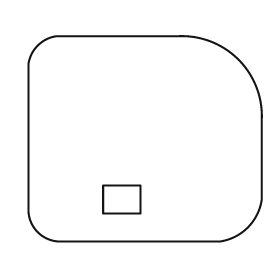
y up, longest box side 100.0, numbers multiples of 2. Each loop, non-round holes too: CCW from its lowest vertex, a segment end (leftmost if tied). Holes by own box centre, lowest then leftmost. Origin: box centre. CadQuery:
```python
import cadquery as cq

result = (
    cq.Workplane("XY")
    .moveTo(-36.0, -44.0)
    .lineTo(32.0, -44.0)
    .threePointArc((44.0, -38.0), (50.0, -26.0))
    .lineTo(50.0, 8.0)
    .threePointArc((40.0, 34.0), (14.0, 44.0))
    .lineTo(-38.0, 44.0)
    .threePointArc((-46.0, 40.0), (-50.0, 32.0))
    .lineTo(-50.0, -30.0)
    .threePointArc((-46.0, -40.0), (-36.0, -44.0))
    .close()
    .moveTo(-18.0, -32.0)
    .lineTo(-2.0, -32.0)
    .lineTo(-2.0, -20.0)
    .lineTo(-18.0, -20.0)
    .close()
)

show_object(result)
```